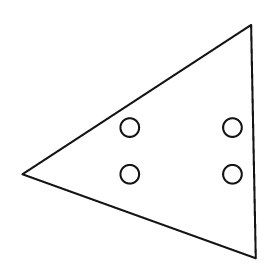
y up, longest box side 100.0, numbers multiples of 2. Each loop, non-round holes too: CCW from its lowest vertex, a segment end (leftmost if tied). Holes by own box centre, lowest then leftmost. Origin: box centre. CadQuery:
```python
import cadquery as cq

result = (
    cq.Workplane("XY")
    .moveTo(50.0, -50.0)
    .lineTo(48.0, 50.0)
    .lineTo(-50.0, -14.0)
    .close()
    .moveTo(-4.0, -14.0)
    .circle(4.0)
    .moveTo(40.0, -14.0)
    .circle(4.0)
    .moveTo(-4.0, 6.0)
    .circle(4.0)
    .moveTo(40.0, 6.0)
    .circle(4.0)
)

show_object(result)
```